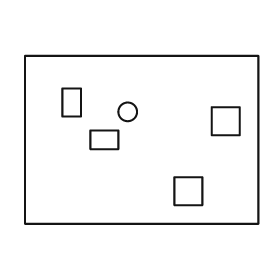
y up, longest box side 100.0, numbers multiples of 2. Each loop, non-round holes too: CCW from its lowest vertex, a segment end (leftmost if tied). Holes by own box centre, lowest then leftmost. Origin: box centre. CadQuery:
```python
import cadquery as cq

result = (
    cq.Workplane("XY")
    .moveTo(-50.0, -36.0)
    .lineTo(50.0, -36.0)
    .lineTo(50.0, 36.0)
    .lineTo(-50.0, 36.0)
    .close()
    .moveTo(14.0, -28.0)
    .lineTo(26.0, -28.0)
    .lineTo(26.0, -16.0)
    .lineTo(14.0, -16.0)
    .close()
    .moveTo(-22.0, -4.0)
    .lineTo(-10.0, -4.0)
    .lineTo(-10.0, 4.0)
    .lineTo(-22.0, 4.0)
    .close()
    .moveTo(30.0, 2.0)
    .lineTo(42.0, 2.0)
    .lineTo(42.0, 14.0)
    .lineTo(30.0, 14.0)
    .close()
    .moveTo(-6.0, 12.0)
    .circle(4.0)
    .moveTo(-34.0, 10.0)
    .lineTo(-26.0, 10.0)
    .lineTo(-26.0, 22.0)
    .lineTo(-34.0, 22.0)
    .close()
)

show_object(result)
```